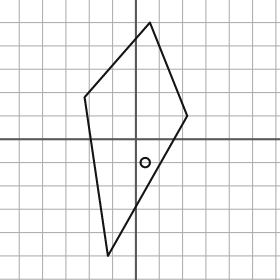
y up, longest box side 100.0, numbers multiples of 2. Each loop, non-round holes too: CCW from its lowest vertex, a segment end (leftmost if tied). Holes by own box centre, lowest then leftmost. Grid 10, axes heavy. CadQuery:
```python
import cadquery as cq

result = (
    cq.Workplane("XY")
    .moveTo(-12.0, -50.0)
    .lineTo(22.0, 10.0)
    .lineTo(6.0, 50.0)
    .lineTo(-22.0, 18.0)
    .close()
    .moveTo(4.0, -10.0)
    .circle(2.0)
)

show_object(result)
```